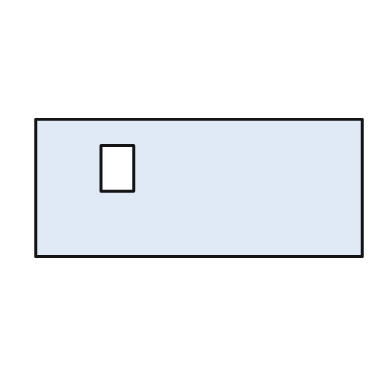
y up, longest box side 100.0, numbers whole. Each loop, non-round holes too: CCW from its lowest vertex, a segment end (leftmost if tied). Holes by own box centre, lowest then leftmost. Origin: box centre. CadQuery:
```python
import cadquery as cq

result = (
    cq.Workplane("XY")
    .moveTo(-50.0, -21.0)
    .lineTo(50.0, -21.0)
    .lineTo(50.0, 21.0)
    .lineTo(-50.0, 21.0)
    .close()
    .moveTo(-30.0, -1.0)
    .lineTo(-20.0, -1.0)
    .lineTo(-20.0, 13.0)
    .lineTo(-30.0, 13.0)
    .close()
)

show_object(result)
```